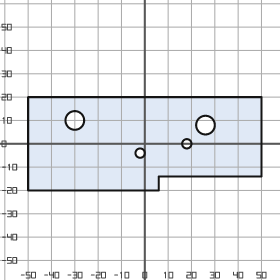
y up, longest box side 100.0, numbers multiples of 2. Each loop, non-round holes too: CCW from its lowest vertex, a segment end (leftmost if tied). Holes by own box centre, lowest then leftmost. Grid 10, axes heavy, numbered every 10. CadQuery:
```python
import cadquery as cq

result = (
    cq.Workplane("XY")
    .moveTo(-50.0, -20.0)
    .lineTo(6.0, -20.0)
    .lineTo(6.0, -14.0)
    .lineTo(50.0, -14.0)
    .lineTo(50.0, 20.0)
    .lineTo(-50.0, 20.0)
    .close()
    .moveTo(-2.0, -4.0)
    .circle(2.0)
    .moveTo(18.0, 0.0)
    .circle(2.0)
    .moveTo(26.0, 8.0)
    .circle(4.0)
    .moveTo(-30.0, 10.0)
    .circle(4.0)
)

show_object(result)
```